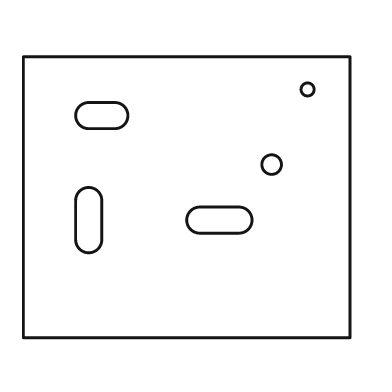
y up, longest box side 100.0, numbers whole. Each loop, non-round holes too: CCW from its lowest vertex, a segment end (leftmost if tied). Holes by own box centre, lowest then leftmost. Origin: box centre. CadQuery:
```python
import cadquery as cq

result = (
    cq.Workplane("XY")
    .moveTo(-50.0, -43.0)
    .lineTo(50.0, -43.0)
    .lineTo(50.0, 43.0)
    .lineTo(-50.0, 43.0)
    .close()
    .moveTo(-34.0, -13.0)
    .threePointArc((-30.0, -17.0), (-26.0, -13.0))
    .lineTo(-26.0, -1.0)
    .threePointArc((-30.0, 3.0), (-34.0, -1.0))
    .close()
    .moveTo(4.0, -11.0)
    .lineTo(16.0, -11.0)
    .threePointArc((20.0, -7.0), (16.0, -3.0))
    .lineTo(4.0, -3.0)
    .threePointArc((0.0, -7.0), (4.0, -11.0))
    .close()
    .moveTo(26.0, 10.0)
    .circle(3.0)
    .moveTo(-30.0, 21.0)
    .lineTo(-22.0, 21.0)
    .threePointArc((-18.0, 25.0), (-22.0, 29.0))
    .lineTo(-30.0, 29.0)
    .threePointArc((-34.0, 25.0), (-30.0, 21.0))
    .close()
    .moveTo(37.0, 33.0)
    .circle(2.0)
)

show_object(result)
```